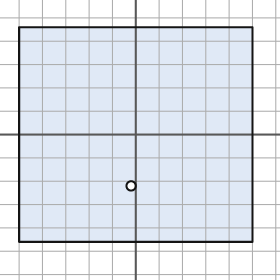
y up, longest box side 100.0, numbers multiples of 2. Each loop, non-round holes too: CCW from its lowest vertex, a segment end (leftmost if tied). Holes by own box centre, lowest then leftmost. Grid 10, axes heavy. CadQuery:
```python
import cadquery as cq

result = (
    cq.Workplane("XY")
    .moveTo(-50.0, -46.0)
    .lineTo(50.0, -46.0)
    .lineTo(50.0, 46.0)
    .lineTo(-50.0, 46.0)
    .close()
    .moveTo(-2.0, -22.0)
    .circle(2.0)
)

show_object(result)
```